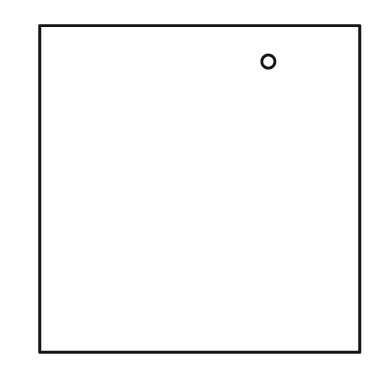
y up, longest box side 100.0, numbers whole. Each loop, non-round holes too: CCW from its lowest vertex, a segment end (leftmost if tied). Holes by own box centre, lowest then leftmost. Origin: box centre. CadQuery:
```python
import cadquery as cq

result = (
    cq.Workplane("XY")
    .moveTo(-49.0, -50.0)
    .lineTo(49.0, -50.0)
    .lineTo(49.0, 50.0)
    .lineTo(-49.0, 50.0)
    .close()
    .moveTo(21.0, 39.0)
    .circle(2.0)
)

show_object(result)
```